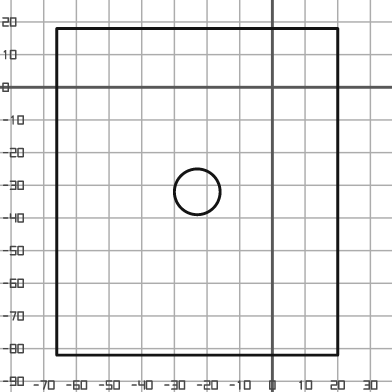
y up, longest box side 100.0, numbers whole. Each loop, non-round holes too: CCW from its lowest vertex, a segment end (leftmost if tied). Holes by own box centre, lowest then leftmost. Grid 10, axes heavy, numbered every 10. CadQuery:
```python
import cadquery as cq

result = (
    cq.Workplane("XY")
    .moveTo(-66.0, -82.0)
    .lineTo(20.0, -82.0)
    .lineTo(20.0, 18.0)
    .lineTo(-66.0, 18.0)
    .close()
    .moveTo(-23.0, -32.0)
    .circle(7.0)
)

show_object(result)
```